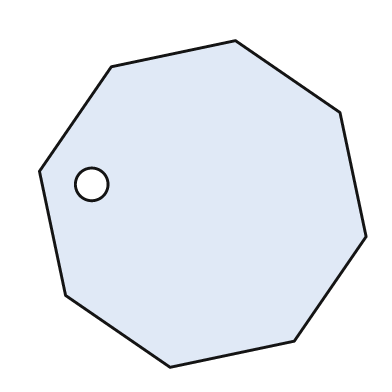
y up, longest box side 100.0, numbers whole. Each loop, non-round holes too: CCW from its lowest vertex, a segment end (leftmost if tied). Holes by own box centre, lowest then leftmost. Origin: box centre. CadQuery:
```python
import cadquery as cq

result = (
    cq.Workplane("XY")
    .moveTo(-10.0, -50.0)
    .lineTo(28.0, -42.0)
    .lineTo(50.0, -10.0)
    .lineTo(42.0, 28.0)
    .lineTo(10.0, 50.0)
    .lineTo(-28.0, 42.0)
    .lineTo(-50.0, 10.0)
    .lineTo(-42.0, -28.0)
    .close()
    .moveTo(-34.0, 6.0)
    .circle(5.0)
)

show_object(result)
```